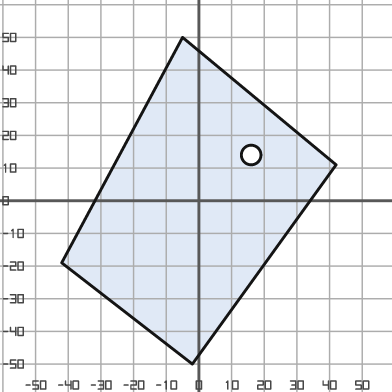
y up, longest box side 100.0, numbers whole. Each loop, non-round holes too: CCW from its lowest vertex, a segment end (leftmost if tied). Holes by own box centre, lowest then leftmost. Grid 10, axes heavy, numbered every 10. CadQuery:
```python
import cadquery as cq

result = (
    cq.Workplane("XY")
    .moveTo(-2.0, -50.0)
    .lineTo(42.0, 11.0)
    .lineTo(-5.0, 50.0)
    .lineTo(-42.0, -19.0)
    .close()
    .moveTo(16.0, 14.0)
    .circle(3.0)
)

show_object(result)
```